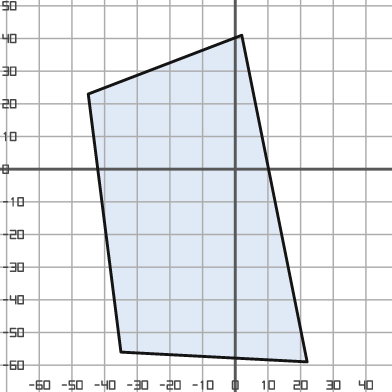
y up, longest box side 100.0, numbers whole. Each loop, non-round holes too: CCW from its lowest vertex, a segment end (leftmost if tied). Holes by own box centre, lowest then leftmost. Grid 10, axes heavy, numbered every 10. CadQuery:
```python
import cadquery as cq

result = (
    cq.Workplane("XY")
    .moveTo(22.0, -59.0)
    .lineTo(2.0, 41.0)
    .lineTo(-45.0, 23.0)
    .lineTo(-35.0, -56.0)
    .close()
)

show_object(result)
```